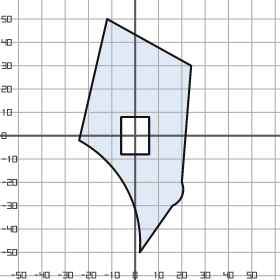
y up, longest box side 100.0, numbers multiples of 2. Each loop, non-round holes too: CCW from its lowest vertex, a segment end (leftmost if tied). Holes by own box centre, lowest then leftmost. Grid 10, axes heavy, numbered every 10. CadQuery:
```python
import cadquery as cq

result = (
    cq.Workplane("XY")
    .moveTo(2.0, -50.0)
    .lineTo(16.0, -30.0)
    .threePointArc((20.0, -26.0), (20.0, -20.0))
    .lineTo(24.0, 30.0)
    .lineTo(-12.0, 50.0)
    .lineTo(-24.0, -2.0)
    .threePointArc((-4.0, -22.0), (2.0, -50.0))
    .close()
    .moveTo(-6.0, -8.0)
    .lineTo(6.0, -8.0)
    .lineTo(6.0, 8.0)
    .lineTo(-6.0, 8.0)
    .close()
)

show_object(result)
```